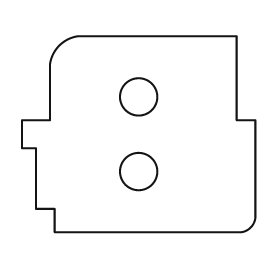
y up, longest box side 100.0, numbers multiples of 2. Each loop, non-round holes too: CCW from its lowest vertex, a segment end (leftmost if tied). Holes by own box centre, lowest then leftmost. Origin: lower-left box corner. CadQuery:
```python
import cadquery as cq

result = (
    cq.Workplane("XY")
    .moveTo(14.0, 0.0)
    .lineTo(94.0, 0.0)
    .threePointArc((98.0, 2.0), (100.0, 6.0))
    .lineTo(100.0, 48.0)
    .lineTo(92.0, 48.0)
    .lineTo(92.0, 84.0)
    .lineTo(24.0, 84.0)
    .threePointArc((16.0, 80.0), (12.0, 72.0))
    .lineTo(12.0, 48.0)
    .lineTo(0.0, 48.0)
    .lineTo(0.0, 36.0)
    .lineTo(6.0, 36.0)
    .lineTo(6.0, 10.0)
    .lineTo(14.0, 10.0)
    .close()
    .moveTo(50.0, 26.0)
    .circle(8.0)
    .moveTo(50.0, 58.0)
    .circle(8.0)
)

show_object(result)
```